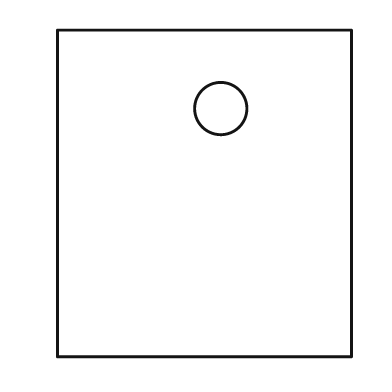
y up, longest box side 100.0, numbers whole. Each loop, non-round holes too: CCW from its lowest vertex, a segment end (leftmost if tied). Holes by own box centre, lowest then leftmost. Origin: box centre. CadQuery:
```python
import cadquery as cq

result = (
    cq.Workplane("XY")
    .moveTo(-45.0, -50.0)
    .lineTo(45.0, -50.0)
    .lineTo(45.0, 50.0)
    .lineTo(-45.0, 50.0)
    .close()
    .moveTo(5.0, 26.0)
    .circle(8.0)
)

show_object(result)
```